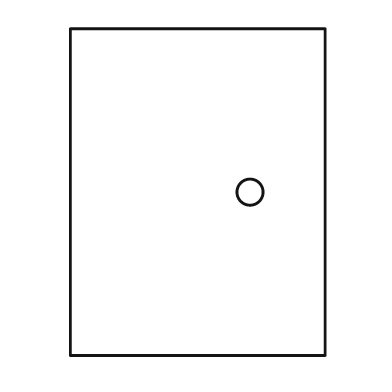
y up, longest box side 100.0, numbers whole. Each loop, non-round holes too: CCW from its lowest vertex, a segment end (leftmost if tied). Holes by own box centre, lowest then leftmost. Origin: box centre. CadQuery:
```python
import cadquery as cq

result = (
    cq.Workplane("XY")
    .moveTo(-39.0, -50.0)
    .lineTo(39.0, -50.0)
    .lineTo(39.0, 50.0)
    .lineTo(-39.0, 50.0)
    .close()
    .moveTo(16.0, 0.0)
    .circle(4.0)
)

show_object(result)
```